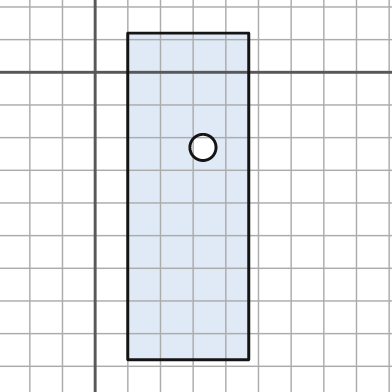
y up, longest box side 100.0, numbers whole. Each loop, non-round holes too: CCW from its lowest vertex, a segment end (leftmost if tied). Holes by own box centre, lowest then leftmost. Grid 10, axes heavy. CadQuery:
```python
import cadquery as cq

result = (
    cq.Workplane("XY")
    .moveTo(10.0, -88.0)
    .lineTo(47.0, -88.0)
    .lineTo(47.0, 12.0)
    .lineTo(10.0, 12.0)
    .close()
    .moveTo(33.0, -23.0)
    .circle(4.0)
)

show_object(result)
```